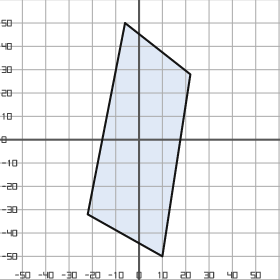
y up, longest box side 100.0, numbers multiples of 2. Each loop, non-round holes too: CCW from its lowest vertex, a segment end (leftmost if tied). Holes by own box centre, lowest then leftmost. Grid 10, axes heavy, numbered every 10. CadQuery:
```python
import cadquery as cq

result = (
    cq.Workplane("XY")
    .moveTo(10.0, -50.0)
    .lineTo(22.0, 28.0)
    .lineTo(-6.0, 50.0)
    .lineTo(-22.0, -32.0)
    .close()
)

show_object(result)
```